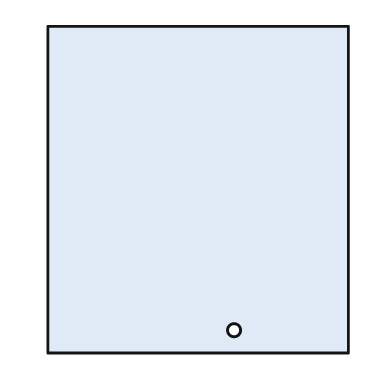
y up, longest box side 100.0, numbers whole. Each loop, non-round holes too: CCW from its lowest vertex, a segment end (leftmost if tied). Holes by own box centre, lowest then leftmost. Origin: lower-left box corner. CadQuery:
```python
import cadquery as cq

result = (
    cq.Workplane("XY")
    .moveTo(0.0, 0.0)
    .lineTo(92.0, 0.0)
    .lineTo(92.0, 100.0)
    .lineTo(0.0, 100.0)
    .close()
    .moveTo(57.0, 7.0)
    .circle(2.0)
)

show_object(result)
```